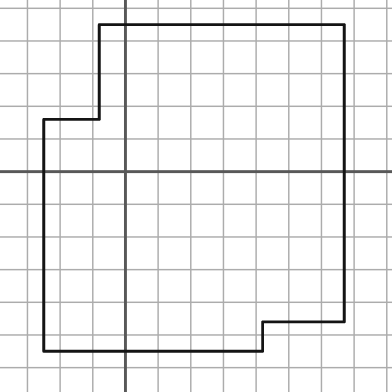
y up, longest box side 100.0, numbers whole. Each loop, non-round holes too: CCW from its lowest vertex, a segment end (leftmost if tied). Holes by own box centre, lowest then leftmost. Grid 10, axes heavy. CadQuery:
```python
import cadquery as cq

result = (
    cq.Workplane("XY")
    .moveTo(-25.0, -55.0)
    .lineTo(42.0, -55.0)
    .lineTo(42.0, -46.0)
    .lineTo(67.0, -46.0)
    .lineTo(67.0, 45.0)
    .lineTo(-8.0, 45.0)
    .lineTo(-8.0, 16.0)
    .lineTo(-25.0, 16.0)
    .close()
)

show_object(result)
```